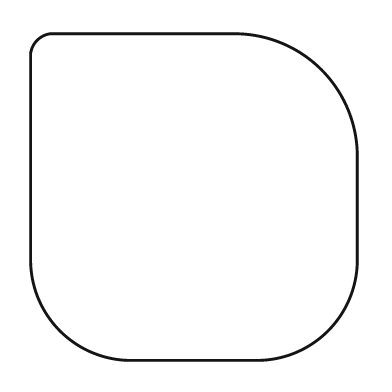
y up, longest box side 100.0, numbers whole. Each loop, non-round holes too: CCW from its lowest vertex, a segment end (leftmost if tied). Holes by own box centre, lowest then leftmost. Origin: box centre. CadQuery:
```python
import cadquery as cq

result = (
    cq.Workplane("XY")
    .moveTo(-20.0, -50.0)
    .lineTo(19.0, -50.0)
    .threePointArc((41.0, -41.0), (50.0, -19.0))
    .lineTo(50.0, 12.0)
    .threePointArc((39.0, 39.0), (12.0, 50.0))
    .lineTo(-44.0, 50.0)
    .threePointArc((-48.0, 48.0), (-50.0, 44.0))
    .lineTo(-50.0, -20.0)
    .threePointArc((-41.0, -41.0), (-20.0, -50.0))
    .close()
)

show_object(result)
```